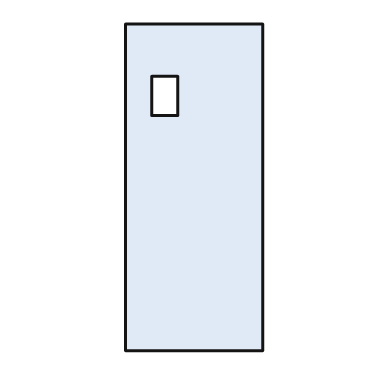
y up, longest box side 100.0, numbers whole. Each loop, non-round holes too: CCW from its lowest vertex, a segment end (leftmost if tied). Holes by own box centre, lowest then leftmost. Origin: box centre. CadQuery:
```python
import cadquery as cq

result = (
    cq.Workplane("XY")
    .moveTo(-21.0, -50.0)
    .lineTo(21.0, -50.0)
    .lineTo(21.0, 50.0)
    .lineTo(-21.0, 50.0)
    .close()
    .moveTo(-13.0, 22.0)
    .lineTo(-5.0, 22.0)
    .lineTo(-5.0, 34.0)
    .lineTo(-13.0, 34.0)
    .close()
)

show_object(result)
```